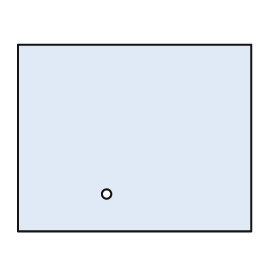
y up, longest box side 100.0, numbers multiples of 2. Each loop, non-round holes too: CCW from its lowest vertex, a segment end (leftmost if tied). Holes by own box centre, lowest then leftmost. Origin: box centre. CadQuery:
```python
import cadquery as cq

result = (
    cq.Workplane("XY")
    .moveTo(-50.0, -40.0)
    .lineTo(50.0, -40.0)
    .lineTo(50.0, 40.0)
    .lineTo(-50.0, 40.0)
    .close()
    .moveTo(-12.0, -24.0)
    .circle(2.0)
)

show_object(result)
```